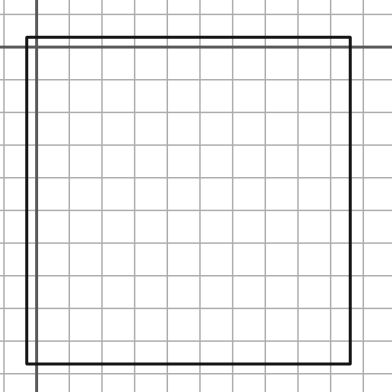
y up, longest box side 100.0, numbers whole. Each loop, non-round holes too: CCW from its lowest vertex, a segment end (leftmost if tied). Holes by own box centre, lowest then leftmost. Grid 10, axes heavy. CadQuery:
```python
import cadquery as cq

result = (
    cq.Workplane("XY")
    .moveTo(-3.0, -97.0)
    .lineTo(96.0, -97.0)
    .lineTo(96.0, 3.0)
    .lineTo(-3.0, 3.0)
    .close()
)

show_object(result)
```